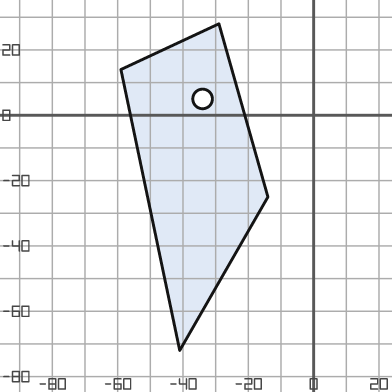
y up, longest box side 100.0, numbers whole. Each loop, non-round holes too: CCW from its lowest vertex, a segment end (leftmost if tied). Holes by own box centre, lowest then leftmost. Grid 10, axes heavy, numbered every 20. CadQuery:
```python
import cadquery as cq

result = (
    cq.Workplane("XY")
    .moveTo(-41.0, -72.0)
    .lineTo(-14.0, -25.0)
    .lineTo(-29.0, 28.0)
    .lineTo(-59.0, 14.0)
    .close()
    .moveTo(-34.0, 5.0)
    .circle(3.0)
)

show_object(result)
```